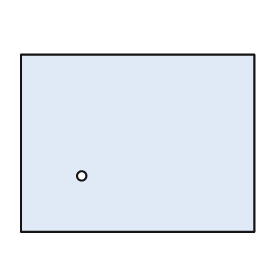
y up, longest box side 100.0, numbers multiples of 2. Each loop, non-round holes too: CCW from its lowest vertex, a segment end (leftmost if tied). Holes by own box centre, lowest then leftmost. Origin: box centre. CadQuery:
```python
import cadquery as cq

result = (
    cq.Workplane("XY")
    .moveTo(-50.0, -38.0)
    .lineTo(50.0, -38.0)
    .lineTo(50.0, 38.0)
    .lineTo(-50.0, 38.0)
    .close()
    .moveTo(-24.0, -14.0)
    .circle(2.0)
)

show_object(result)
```